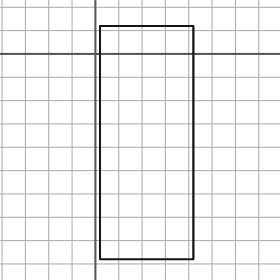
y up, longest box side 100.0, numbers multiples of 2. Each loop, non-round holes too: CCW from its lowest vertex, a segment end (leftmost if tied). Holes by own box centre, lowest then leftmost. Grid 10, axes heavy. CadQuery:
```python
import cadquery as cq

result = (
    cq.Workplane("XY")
    .moveTo(2.0, -88.0)
    .lineTo(42.0, -88.0)
    .lineTo(42.0, 12.0)
    .lineTo(2.0, 12.0)
    .close()
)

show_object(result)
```